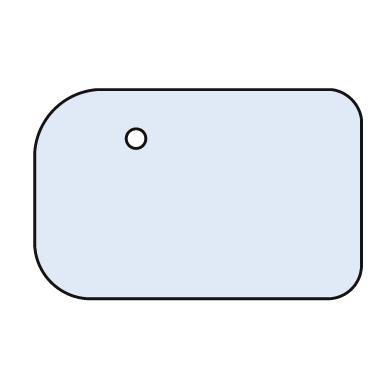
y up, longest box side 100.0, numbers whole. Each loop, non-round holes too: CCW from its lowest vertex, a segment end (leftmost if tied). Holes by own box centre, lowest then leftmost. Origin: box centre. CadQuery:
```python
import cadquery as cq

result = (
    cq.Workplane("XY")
    .moveTo(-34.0, -32.0)
    .lineTo(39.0, -32.0)
    .threePointArc((47.0, -29.0), (50.0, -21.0))
    .lineTo(50.0, 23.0)
    .threePointArc((47.0, 29.0), (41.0, 32.0))
    .lineTo(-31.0, 32.0)
    .threePointArc((-44.0, 26.0), (-50.0, 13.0))
    .lineTo(-50.0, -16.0)
    .threePointArc((-45.0, -27.0), (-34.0, -32.0))
    .close()
    .moveTo(-19.0, 17.0)
    .circle(3.0)
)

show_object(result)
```